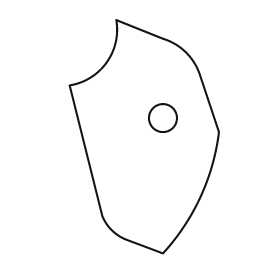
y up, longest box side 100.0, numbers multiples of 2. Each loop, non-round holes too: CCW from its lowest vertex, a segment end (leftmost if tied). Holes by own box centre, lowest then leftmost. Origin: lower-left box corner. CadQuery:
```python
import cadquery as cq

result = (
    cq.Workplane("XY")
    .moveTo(40.0, 0.0)
    .threePointArc((56.0, 24.0), (64.0, 52.0))
    .lineTo(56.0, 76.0)
    .threePointArc((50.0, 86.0), (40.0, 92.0))
    .lineTo(20.0, 100.0)
    .threePointArc((16.0, 82.0), (0.0, 72.0))
    .lineTo(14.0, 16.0)
    .threePointArc((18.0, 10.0), (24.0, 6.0))
    .close()
    .moveTo(40.0, 58.0)
    .circle(6.0)
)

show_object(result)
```